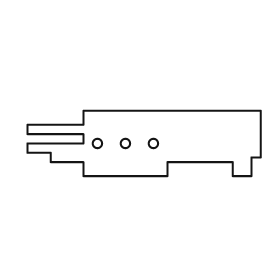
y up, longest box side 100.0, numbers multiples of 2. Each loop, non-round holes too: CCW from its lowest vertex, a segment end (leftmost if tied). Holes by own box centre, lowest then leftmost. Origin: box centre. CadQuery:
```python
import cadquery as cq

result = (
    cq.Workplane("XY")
    .moveTo(-26.0, -14.0)
    .lineTo(10.0, -14.0)
    .lineTo(10.0, -8.0)
    .lineTo(38.0, -8.0)
    .lineTo(38.0, -14.0)
    .lineTo(46.0, -14.0)
    .lineTo(46.0, -6.0)
    .lineTo(50.0, -6.0)
    .lineTo(50.0, 14.0)
    .lineTo(-26.0, 14.0)
    .lineTo(-26.0, 8.0)
    .lineTo(-50.0, 8.0)
    .lineTo(-50.0, 4.0)
    .lineTo(-26.0, 4.0)
    .lineTo(-26.0, 0.0)
    .lineTo(-50.0, 0.0)
    .lineTo(-50.0, -4.0)
    .lineTo(-40.0, -4.0)
    .lineTo(-40.0, -8.0)
    .lineTo(-26.0, -8.0)
    .close()
    .moveTo(-20.0, 0.0)
    .circle(2.0)
    .moveTo(-8.0, 0.0)
    .circle(2.0)
    .moveTo(4.0, 0.0)
    .circle(2.0)
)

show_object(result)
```